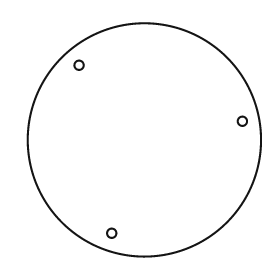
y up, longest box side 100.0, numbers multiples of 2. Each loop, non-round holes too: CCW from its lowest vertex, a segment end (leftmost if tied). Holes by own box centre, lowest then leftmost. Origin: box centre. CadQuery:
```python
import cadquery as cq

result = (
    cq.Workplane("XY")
    .moveTo(0.0, 0.0)
    .circle(50.0)
    .moveTo(-14.0, -40.0)
    .circle(2.0)
    .moveTo(42.0, 8.0)
    .circle(2.0)
    .moveTo(-28.0, 32.0)
    .circle(2.0)
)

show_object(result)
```